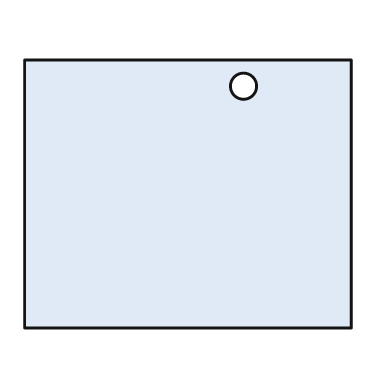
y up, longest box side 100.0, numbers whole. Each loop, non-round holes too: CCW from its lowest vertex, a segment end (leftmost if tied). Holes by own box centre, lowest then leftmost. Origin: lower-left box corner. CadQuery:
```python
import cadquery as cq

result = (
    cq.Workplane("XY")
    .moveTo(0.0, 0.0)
    .lineTo(100.0, 0.0)
    .lineTo(100.0, 82.0)
    .lineTo(0.0, 82.0)
    .close()
    .moveTo(67.0, 74.0)
    .circle(4.0)
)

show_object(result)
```